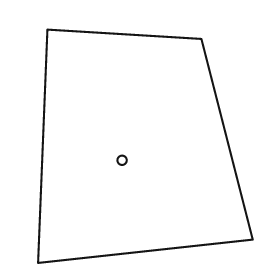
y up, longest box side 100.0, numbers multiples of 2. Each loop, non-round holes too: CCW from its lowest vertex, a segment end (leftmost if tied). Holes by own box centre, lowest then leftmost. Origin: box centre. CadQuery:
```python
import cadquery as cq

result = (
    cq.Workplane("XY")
    .moveTo(-46.0, -50.0)
    .lineTo(46.0, -40.0)
    .lineTo(24.0, 46.0)
    .lineTo(-42.0, 50.0)
    .close()
    .moveTo(-10.0, -6.0)
    .circle(2.0)
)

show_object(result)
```